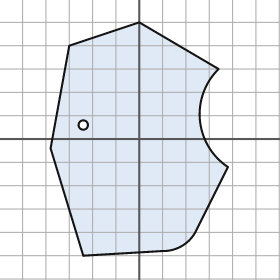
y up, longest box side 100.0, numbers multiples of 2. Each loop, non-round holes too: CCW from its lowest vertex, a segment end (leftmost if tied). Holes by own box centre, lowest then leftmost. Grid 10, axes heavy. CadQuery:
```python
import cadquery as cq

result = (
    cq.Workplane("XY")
    .moveTo(-24.0, -50.0)
    .lineTo(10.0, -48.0)
    .threePointArc((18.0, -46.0), (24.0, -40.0))
    .lineTo(38.0, -12.0)
    .threePointArc((26.0, 8.0), (34.0, 30.0))
    .lineTo(0.0, 50.0)
    .lineTo(-30.0, 40.0)
    .lineTo(-38.0, -4.0)
    .close()
    .moveTo(-24.0, 6.0)
    .circle(2.0)
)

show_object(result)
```